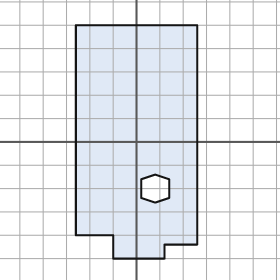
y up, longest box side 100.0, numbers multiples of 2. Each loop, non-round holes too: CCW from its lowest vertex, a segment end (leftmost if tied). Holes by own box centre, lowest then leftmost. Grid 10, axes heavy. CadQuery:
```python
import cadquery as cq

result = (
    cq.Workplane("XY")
    .moveTo(-10.0, -50.0)
    .lineTo(12.0, -50.0)
    .lineTo(12.0, -44.0)
    .lineTo(26.0, -44.0)
    .lineTo(26.0, 50.0)
    .lineTo(-26.0, 50.0)
    .lineTo(-26.0, -40.0)
    .lineTo(-10.0, -40.0)
    .close()
    .moveTo(8.0, -26.0)
    .lineTo(14.0, -24.0)
    .lineTo(14.0, -16.0)
    .lineTo(8.0, -14.0)
    .lineTo(2.0, -16.0)
    .lineTo(2.0, -24.0)
    .close()
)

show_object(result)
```